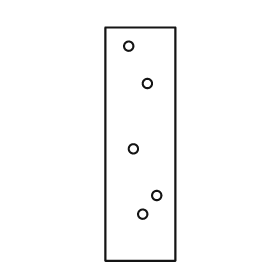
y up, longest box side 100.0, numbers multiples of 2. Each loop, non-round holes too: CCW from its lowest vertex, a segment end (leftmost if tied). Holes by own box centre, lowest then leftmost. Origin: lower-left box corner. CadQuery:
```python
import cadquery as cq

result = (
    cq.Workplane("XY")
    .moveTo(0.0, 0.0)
    .lineTo(30.0, 0.0)
    .lineTo(30.0, 100.0)
    .lineTo(0.0, 100.0)
    .close()
    .moveTo(16.0, 20.0)
    .circle(2.0)
    .moveTo(22.0, 28.0)
    .circle(2.0)
    .moveTo(12.0, 48.0)
    .circle(2.0)
    .moveTo(18.0, 76.0)
    .circle(2.0)
    .moveTo(10.0, 92.0)
    .circle(2.0)
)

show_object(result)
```